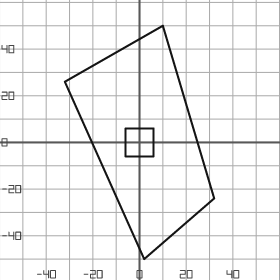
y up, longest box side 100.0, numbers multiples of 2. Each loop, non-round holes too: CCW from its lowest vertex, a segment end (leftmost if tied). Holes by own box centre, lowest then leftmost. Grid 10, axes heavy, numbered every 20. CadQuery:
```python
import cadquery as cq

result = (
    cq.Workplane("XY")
    .moveTo(2.0, -50.0)
    .lineTo(32.0, -24.0)
    .lineTo(10.0, 50.0)
    .lineTo(-32.0, 26.0)
    .close()
    .moveTo(-6.0, -6.0)
    .lineTo(6.0, -6.0)
    .lineTo(6.0, 6.0)
    .lineTo(-6.0, 6.0)
    .close()
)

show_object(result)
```